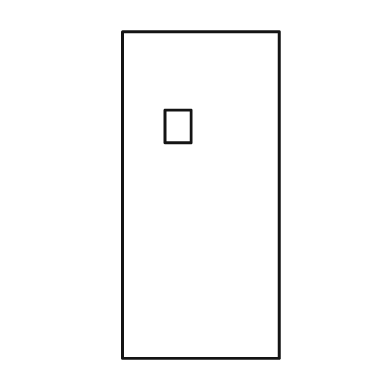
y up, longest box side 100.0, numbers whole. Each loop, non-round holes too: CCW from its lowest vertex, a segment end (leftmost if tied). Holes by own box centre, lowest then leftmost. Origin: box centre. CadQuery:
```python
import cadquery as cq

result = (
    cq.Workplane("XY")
    .moveTo(-24.0, -50.0)
    .lineTo(24.0, -50.0)
    .lineTo(24.0, 50.0)
    .lineTo(-24.0, 50.0)
    .close()
    .moveTo(-11.0, 16.0)
    .lineTo(-3.0, 16.0)
    .lineTo(-3.0, 26.0)
    .lineTo(-11.0, 26.0)
    .close()
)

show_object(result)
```